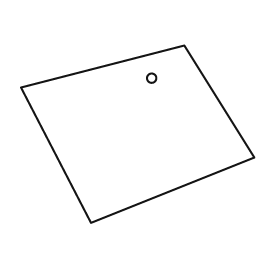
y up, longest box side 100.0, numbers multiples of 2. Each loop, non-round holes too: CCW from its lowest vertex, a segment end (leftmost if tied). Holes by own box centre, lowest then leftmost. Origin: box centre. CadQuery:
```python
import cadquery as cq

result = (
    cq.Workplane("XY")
    .moveTo(-20.0, -38.0)
    .lineTo(50.0, -10.0)
    .lineTo(20.0, 38.0)
    .lineTo(-50.0, 20.0)
    .close()
    .moveTo(6.0, 24.0)
    .circle(2.0)
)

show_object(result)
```